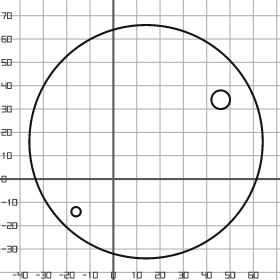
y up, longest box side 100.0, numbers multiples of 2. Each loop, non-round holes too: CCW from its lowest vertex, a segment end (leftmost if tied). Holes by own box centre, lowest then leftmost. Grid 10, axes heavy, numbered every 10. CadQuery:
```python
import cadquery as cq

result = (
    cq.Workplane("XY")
    .moveTo(14.0, 16.0)
    .circle(50.0)
    .moveTo(-16.0, -14.0)
    .circle(2.0)
    .moveTo(46.0, 34.0)
    .circle(4.0)
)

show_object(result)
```